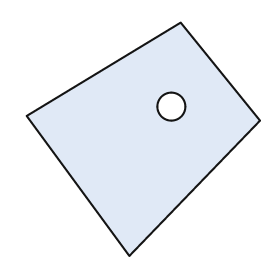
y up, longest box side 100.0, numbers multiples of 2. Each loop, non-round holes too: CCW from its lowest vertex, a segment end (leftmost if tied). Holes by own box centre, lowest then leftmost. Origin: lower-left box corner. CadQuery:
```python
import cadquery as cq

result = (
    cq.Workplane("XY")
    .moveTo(44.0, 0.0)
    .lineTo(100.0, 58.0)
    .lineTo(66.0, 100.0)
    .lineTo(0.0, 60.0)
    .close()
    .moveTo(62.0, 64.0)
    .circle(6.0)
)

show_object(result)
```